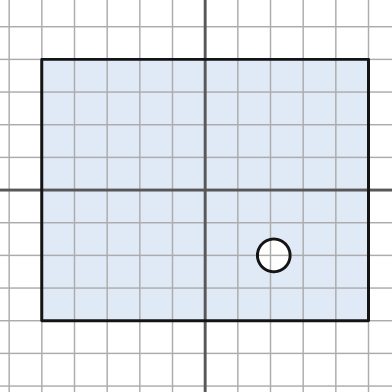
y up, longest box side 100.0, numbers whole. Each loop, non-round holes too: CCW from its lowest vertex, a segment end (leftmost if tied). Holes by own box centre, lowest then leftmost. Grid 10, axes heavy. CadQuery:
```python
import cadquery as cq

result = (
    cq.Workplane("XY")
    .moveTo(-50.0, -40.0)
    .lineTo(50.0, -40.0)
    .lineTo(50.0, 40.0)
    .lineTo(-50.0, 40.0)
    .close()
    .moveTo(21.0, -20.0)
    .circle(5.0)
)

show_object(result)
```